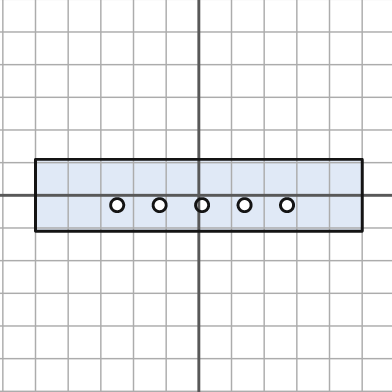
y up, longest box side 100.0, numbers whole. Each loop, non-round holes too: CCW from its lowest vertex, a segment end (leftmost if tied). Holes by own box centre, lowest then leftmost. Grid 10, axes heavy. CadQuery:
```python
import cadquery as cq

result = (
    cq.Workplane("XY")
    .moveTo(-50.0, -11.0)
    .lineTo(50.0, -11.0)
    .lineTo(50.0, 11.0)
    .lineTo(-50.0, 11.0)
    .close()
    .moveTo(-25.0, -3.0)
    .circle(2.0)
    .moveTo(-12.0, -3.0)
    .circle(2.0)
    .moveTo(1.0, -3.0)
    .circle(2.0)
    .moveTo(14.0, -3.0)
    .circle(2.0)
    .moveTo(27.0, -3.0)
    .circle(2.0)
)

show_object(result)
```